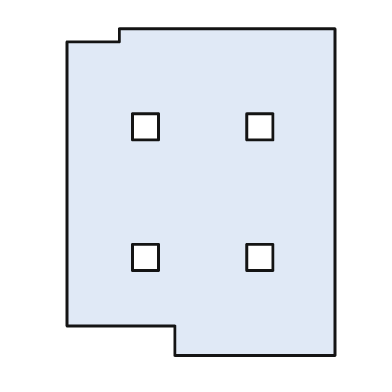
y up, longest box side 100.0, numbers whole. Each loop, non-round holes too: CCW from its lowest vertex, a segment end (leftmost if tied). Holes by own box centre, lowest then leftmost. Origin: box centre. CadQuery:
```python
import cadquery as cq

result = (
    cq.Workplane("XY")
    .moveTo(-8.0, -50.0)
    .lineTo(41.0, -50.0)
    .lineTo(41.0, 50.0)
    .lineTo(-25.0, 50.0)
    .lineTo(-25.0, 46.0)
    .lineTo(-41.0, 46.0)
    .lineTo(-41.0, -41.0)
    .lineTo(-8.0, -41.0)
    .close()
    .moveTo(-21.0, -24.0)
    .lineTo(-13.0, -24.0)
    .lineTo(-13.0, -16.0)
    .lineTo(-21.0, -16.0)
    .close()
    .moveTo(14.0, -24.0)
    .lineTo(22.0, -24.0)
    .lineTo(22.0, -16.0)
    .lineTo(14.0, -16.0)
    .close()
    .moveTo(-21.0, 16.0)
    .lineTo(-13.0, 16.0)
    .lineTo(-13.0, 24.0)
    .lineTo(-21.0, 24.0)
    .close()
    .moveTo(14.0, 16.0)
    .lineTo(22.0, 16.0)
    .lineTo(22.0, 24.0)
    .lineTo(14.0, 24.0)
    .close()
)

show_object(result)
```